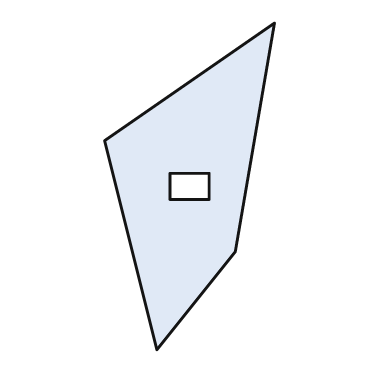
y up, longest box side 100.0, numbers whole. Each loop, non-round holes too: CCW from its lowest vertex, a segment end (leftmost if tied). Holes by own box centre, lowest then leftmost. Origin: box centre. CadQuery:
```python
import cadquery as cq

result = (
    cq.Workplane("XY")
    .moveTo(-10.0, -50.0)
    .lineTo(14.0, -20.0)
    .lineTo(26.0, 50.0)
    .lineTo(-26.0, 14.0)
    .close()
    .moveTo(-6.0, -4.0)
    .lineTo(6.0, -4.0)
    .lineTo(6.0, 4.0)
    .lineTo(-6.0, 4.0)
    .close()
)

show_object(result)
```